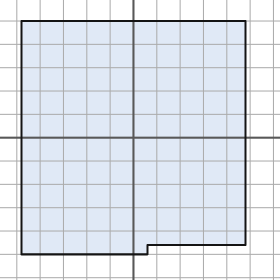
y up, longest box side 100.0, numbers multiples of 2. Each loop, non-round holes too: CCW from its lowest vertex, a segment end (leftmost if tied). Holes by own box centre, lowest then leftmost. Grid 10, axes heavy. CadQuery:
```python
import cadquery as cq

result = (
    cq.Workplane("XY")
    .moveTo(-48.0, -50.0)
    .lineTo(6.0, -50.0)
    .lineTo(6.0, -46.0)
    .lineTo(48.0, -46.0)
    .lineTo(48.0, 50.0)
    .lineTo(-48.0, 50.0)
    .close()
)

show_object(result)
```